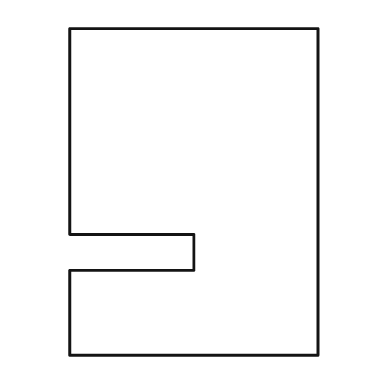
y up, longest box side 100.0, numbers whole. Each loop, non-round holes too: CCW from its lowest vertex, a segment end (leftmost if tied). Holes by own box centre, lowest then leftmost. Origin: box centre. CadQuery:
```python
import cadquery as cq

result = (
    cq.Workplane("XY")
    .moveTo(-38.0, -50.0)
    .lineTo(38.0, -50.0)
    .lineTo(38.0, 50.0)
    .lineTo(-38.0, 50.0)
    .lineTo(-38.0, -13.0)
    .lineTo(0.0, -13.0)
    .lineTo(0.0, -24.0)
    .lineTo(-38.0, -24.0)
    .close()
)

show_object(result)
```